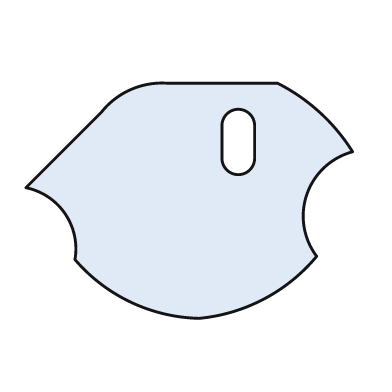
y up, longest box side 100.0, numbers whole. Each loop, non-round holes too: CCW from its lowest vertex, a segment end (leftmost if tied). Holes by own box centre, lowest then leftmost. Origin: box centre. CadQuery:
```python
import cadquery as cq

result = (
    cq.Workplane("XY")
    .moveTo(3.0, -36.0)
    .threePointArc((23.0, -30.0), (39.0, -17.0))
    .threePointArc((36.0, 2.0), (50.0, 15.0))
    .threePointArc((40.0, 27.0), (27.0, 36.0))
    .lineTo(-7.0, 36.0)
    .threePointArc((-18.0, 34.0), (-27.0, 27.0))
    .lineTo(-50.0, 4.0)
    .threePointArc((-38.0, -4.0), (-35.0, -18.0))
    .threePointArc((-18.0, -31.0), (3.0, -36.0))
    .close()
    .moveTo(10.0, 13.0)
    .threePointArc((15.0, 8.0), (20.0, 13.0))
    .lineTo(20.0, 23.0)
    .threePointArc((15.0, 28.0), (10.0, 23.0))
    .close()
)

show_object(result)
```